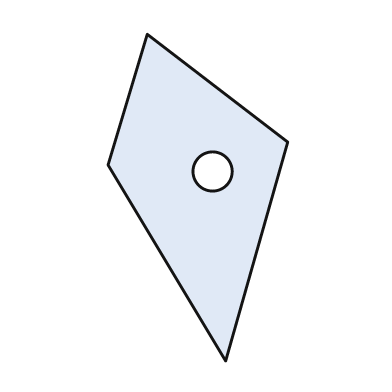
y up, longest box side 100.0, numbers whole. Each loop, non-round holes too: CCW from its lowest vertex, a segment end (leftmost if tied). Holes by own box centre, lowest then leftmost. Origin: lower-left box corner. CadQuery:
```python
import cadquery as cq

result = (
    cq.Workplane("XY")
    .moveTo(36.0, 0.0)
    .lineTo(55.0, 67.0)
    .lineTo(12.0, 100.0)
    .lineTo(0.0, 60.0)
    .close()
    .moveTo(32.0, 58.0)
    .circle(6.0)
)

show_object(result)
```